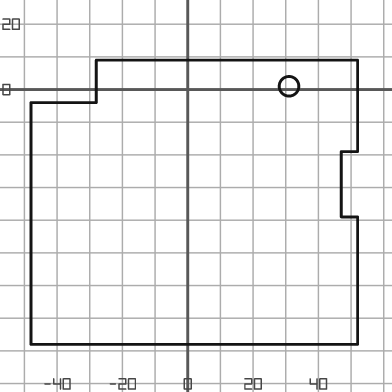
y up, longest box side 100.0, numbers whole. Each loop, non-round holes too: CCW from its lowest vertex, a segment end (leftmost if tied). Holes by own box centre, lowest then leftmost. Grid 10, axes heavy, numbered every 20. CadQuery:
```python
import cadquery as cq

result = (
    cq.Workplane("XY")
    .moveTo(-48.0, -78.0)
    .lineTo(52.0, -78.0)
    .lineTo(52.0, -39.0)
    .lineTo(47.0, -39.0)
    .lineTo(47.0, -19.0)
    .lineTo(52.0, -19.0)
    .lineTo(52.0, 9.0)
    .lineTo(-28.0, 9.0)
    .lineTo(-28.0, -4.0)
    .lineTo(-48.0, -4.0)
    .close()
    .moveTo(31.0, 1.0)
    .circle(3.0)
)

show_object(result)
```